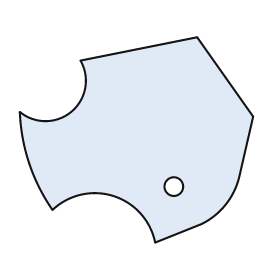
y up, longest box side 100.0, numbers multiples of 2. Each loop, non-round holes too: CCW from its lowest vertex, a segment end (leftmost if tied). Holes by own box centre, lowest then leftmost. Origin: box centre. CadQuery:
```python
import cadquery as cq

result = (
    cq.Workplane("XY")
    .moveTo(8.0, -44.0)
    .lineTo(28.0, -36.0)
    .threePointArc((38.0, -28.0), (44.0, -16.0))
    .lineTo(50.0, 10.0)
    .lineTo(26.0, 44.0)
    .lineTo(-24.0, 34.0)
    .threePointArc((-28.0, 12.0), (-50.0, 12.0))
    .threePointArc((-46.0, -10.0), (-36.0, -30.0))
    .threePointArc((-10.0, -24.0), (8.0, -44.0))
    .close()
    .moveTo(16.0, -20.0)
    .circle(4.0)
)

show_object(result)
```